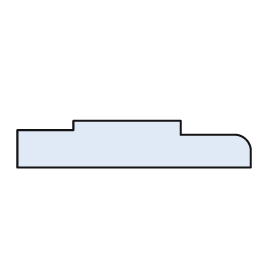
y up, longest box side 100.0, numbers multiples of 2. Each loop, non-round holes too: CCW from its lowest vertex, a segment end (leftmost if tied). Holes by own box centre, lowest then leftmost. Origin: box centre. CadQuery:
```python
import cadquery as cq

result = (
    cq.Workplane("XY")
    .moveTo(-50.0, -10.0)
    .lineTo(50.0, -10.0)
    .lineTo(50.0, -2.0)
    .threePointArc((48.0, 2.0), (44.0, 4.0))
    .lineTo(20.0, 4.0)
    .lineTo(20.0, 10.0)
    .lineTo(-26.0, 10.0)
    .lineTo(-26.0, 6.0)
    .lineTo(-50.0, 6.0)
    .close()
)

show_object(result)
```